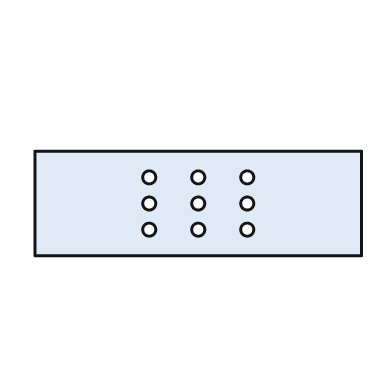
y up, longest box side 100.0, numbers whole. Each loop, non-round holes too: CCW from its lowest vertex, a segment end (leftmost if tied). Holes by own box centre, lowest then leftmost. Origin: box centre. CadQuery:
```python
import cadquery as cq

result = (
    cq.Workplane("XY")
    .moveTo(-50.0, -16.0)
    .lineTo(50.0, -16.0)
    .lineTo(50.0, 16.0)
    .lineTo(-50.0, 16.0)
    .close()
    .moveTo(-15.0, -8.0)
    .circle(2.0)
    .moveTo(0.0, -8.0)
    .circle(2.0)
    .moveTo(15.0, -8.0)
    .circle(2.0)
    .moveTo(-15.0, 0.0)
    .circle(2.0)
    .moveTo(0.0, 0.0)
    .circle(2.0)
    .moveTo(15.0, 0.0)
    .circle(2.0)
    .moveTo(-15.0, 8.0)
    .circle(2.0)
    .moveTo(0.0, 8.0)
    .circle(2.0)
    .moveTo(15.0, 8.0)
    .circle(2.0)
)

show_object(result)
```